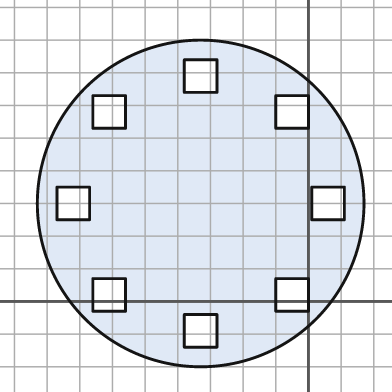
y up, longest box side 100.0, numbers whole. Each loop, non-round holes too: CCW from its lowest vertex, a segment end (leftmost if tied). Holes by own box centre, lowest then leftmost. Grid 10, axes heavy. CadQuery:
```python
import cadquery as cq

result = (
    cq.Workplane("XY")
    .moveTo(-33.0, 30.0)
    .circle(50.0)
    .moveTo(-38.0, -14.0)
    .lineTo(-28.0, -14.0)
    .lineTo(-28.0, -4.0)
    .lineTo(-38.0, -4.0)
    .close()
    .moveTo(-66.0, -3.0)
    .lineTo(-56.0, -3.0)
    .lineTo(-56.0, 7.0)
    .lineTo(-66.0, 7.0)
    .close()
    .moveTo(-10.0, -3.0)
    .lineTo(0.0, -3.0)
    .lineTo(0.0, 7.0)
    .lineTo(-10.0, 7.0)
    .close()
    .moveTo(-77.0, 25.0)
    .lineTo(-67.0, 25.0)
    .lineTo(-67.0, 35.0)
    .lineTo(-77.0, 35.0)
    .close()
    .moveTo(1.0, 25.0)
    .lineTo(11.0, 25.0)
    .lineTo(11.0, 35.0)
    .lineTo(1.0, 35.0)
    .close()
    .moveTo(-66.0, 53.0)
    .lineTo(-56.0, 53.0)
    .lineTo(-56.0, 63.0)
    .lineTo(-66.0, 63.0)
    .close()
    .moveTo(-10.0, 53.0)
    .lineTo(0.0, 53.0)
    .lineTo(0.0, 63.0)
    .lineTo(-10.0, 63.0)
    .close()
    .moveTo(-38.0, 64.0)
    .lineTo(-28.0, 64.0)
    .lineTo(-28.0, 74.0)
    .lineTo(-38.0, 74.0)
    .close()
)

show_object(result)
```